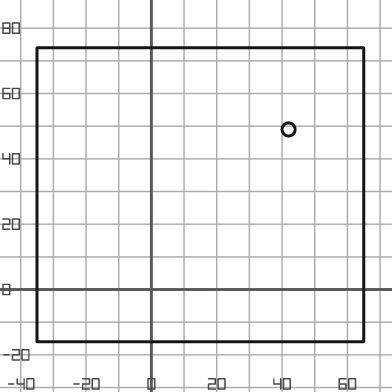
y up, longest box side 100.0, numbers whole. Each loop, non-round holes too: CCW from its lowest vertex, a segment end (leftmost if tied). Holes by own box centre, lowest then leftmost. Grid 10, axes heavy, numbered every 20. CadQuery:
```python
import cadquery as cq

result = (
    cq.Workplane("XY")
    .moveTo(-35.0, -16.0)
    .lineTo(65.0, -16.0)
    .lineTo(65.0, 74.0)
    .lineTo(-35.0, 74.0)
    .close()
    .moveTo(42.0, 49.0)
    .circle(2.0)
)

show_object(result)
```